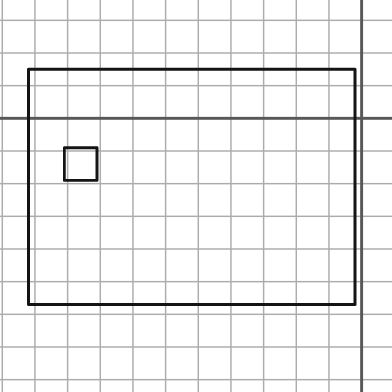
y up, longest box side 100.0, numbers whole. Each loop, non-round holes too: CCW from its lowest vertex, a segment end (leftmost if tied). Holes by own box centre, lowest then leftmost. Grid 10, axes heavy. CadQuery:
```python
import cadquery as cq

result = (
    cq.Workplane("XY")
    .moveTo(-102.0, -57.0)
    .lineTo(-2.0, -57.0)
    .lineTo(-2.0, 15.0)
    .lineTo(-102.0, 15.0)
    .close()
    .moveTo(-91.0, -19.0)
    .lineTo(-81.0, -19.0)
    .lineTo(-81.0, -9.0)
    .lineTo(-91.0, -9.0)
    .close()
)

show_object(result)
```